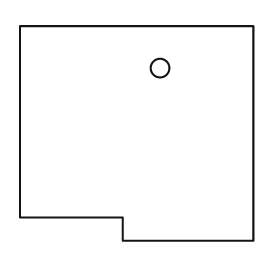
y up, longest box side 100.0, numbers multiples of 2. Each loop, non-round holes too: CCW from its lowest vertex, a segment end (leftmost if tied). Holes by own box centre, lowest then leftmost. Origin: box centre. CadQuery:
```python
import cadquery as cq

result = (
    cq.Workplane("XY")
    .moveTo(-6.0, -46.0)
    .lineTo(50.0, -46.0)
    .lineTo(50.0, 46.0)
    .lineTo(-50.0, 46.0)
    .lineTo(-50.0, -36.0)
    .lineTo(-6.0, -36.0)
    .close()
    .moveTo(10.0, 28.0)
    .circle(4.0)
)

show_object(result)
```